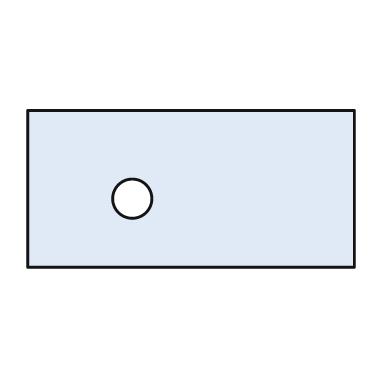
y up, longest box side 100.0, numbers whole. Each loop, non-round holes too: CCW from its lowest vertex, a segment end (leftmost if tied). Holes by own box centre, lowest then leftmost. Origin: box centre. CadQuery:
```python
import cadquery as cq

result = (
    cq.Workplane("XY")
    .moveTo(-50.0, -24.0)
    .lineTo(50.0, -24.0)
    .lineTo(50.0, 24.0)
    .lineTo(-50.0, 24.0)
    .close()
    .moveTo(-18.0, -3.0)
    .circle(6.0)
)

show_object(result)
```